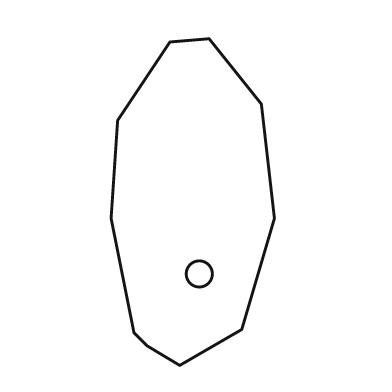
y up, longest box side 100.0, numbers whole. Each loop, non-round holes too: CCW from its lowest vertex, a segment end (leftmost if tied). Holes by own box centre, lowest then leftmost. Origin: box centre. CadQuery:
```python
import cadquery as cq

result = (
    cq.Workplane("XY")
    .moveTo(-4.0, -50.0)
    .lineTo(15.0, -39.0)
    .lineTo(25.0, -5.0)
    .lineTo(21.0, 30.0)
    .lineTo(5.0, 50.0)
    .lineTo(-7.0, 49.0)
    .lineTo(-23.0, 25.0)
    .lineTo(-25.0, -5.0)
    .lineTo(-18.0, -40.0)
    .lineTo(-14.0, -44.0)
    .close()
    .moveTo(2.0, -22.0)
    .circle(4.0)
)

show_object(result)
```